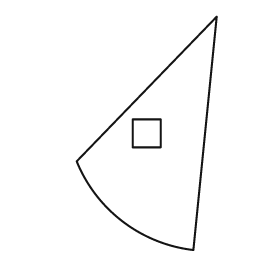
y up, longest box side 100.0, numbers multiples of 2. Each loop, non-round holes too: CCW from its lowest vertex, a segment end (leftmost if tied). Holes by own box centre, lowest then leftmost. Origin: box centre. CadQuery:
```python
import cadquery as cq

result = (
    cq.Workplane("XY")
    .moveTo(20.0, -50.0)
    .lineTo(30.0, 50.0)
    .lineTo(-30.0, -12.0)
    .threePointArc((-10.0, -38.0), (20.0, -50.0))
    .close()
    .moveTo(-6.0, -6.0)
    .lineTo(6.0, -6.0)
    .lineTo(6.0, 6.0)
    .lineTo(-6.0, 6.0)
    .close()
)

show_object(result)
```